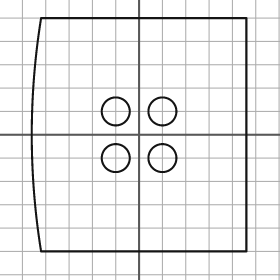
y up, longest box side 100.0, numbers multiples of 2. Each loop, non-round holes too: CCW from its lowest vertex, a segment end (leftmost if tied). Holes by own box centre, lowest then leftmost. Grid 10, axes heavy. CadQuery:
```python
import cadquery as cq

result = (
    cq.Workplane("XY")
    .moveTo(-42.0, -50.0)
    .lineTo(46.0, -50.0)
    .lineTo(46.0, 50.0)
    .lineTo(-42.0, 50.0)
    .threePointArc((-46.0, 0.0), (-42.0, -50.0))
    .close()
    .moveTo(-10.0, -10.0)
    .circle(6.0)
    .moveTo(10.0, -10.0)
    .circle(6.0)
    .moveTo(-10.0, 10.0)
    .circle(6.0)
    .moveTo(10.0, 10.0)
    .circle(6.0)
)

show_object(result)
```